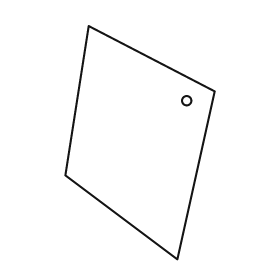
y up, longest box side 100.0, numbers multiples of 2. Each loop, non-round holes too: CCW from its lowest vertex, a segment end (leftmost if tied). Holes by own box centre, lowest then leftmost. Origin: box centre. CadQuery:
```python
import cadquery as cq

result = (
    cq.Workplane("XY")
    .moveTo(16.0, -50.0)
    .lineTo(32.0, 22.0)
    .lineTo(-22.0, 50.0)
    .lineTo(-32.0, -14.0)
    .close()
    .moveTo(20.0, 18.0)
    .circle(2.0)
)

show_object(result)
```